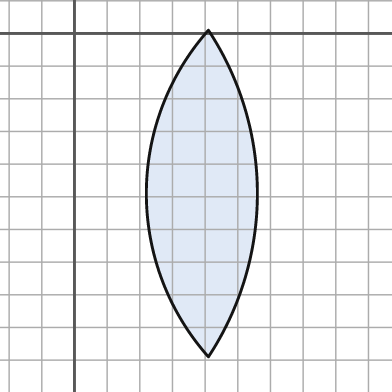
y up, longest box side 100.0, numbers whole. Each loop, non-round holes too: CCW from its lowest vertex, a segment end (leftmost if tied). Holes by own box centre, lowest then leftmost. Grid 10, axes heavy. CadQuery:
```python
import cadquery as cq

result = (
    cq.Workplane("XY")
    .moveTo(41.0, -99.0)
    .threePointArc((56.0, -49.0), (41.0, 1.0))
    .threePointArc((22.0, -49.0), (41.0, -99.0))
    .close()
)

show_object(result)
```